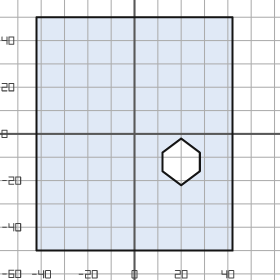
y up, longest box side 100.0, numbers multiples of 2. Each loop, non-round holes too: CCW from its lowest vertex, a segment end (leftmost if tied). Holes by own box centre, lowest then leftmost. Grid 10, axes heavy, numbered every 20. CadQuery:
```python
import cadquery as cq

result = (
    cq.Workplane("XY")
    .moveTo(-42.0, -50.0)
    .lineTo(42.0, -50.0)
    .lineTo(42.0, 50.0)
    .lineTo(-42.0, 50.0)
    .close()
    .moveTo(20.0, -22.0)
    .lineTo(28.0, -16.0)
    .lineTo(28.0, -8.0)
    .lineTo(20.0, -2.0)
    .lineTo(12.0, -8.0)
    .lineTo(12.0, -16.0)
    .close()
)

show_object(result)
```